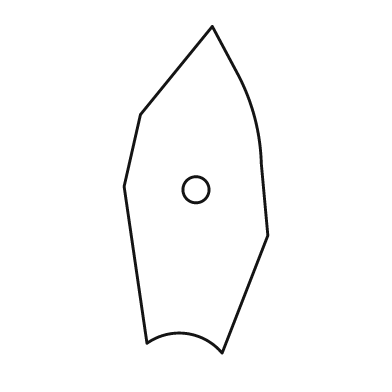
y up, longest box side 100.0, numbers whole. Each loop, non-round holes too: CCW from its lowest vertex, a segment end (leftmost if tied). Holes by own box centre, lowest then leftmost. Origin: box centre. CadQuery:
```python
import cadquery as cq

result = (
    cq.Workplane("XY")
    .moveTo(8.0, -50.0)
    .lineTo(22.0, -14.0)
    .lineTo(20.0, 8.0)
    .threePointArc((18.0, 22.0), (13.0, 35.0))
    .lineTo(5.0, 50.0)
    .lineTo(-17.0, 23.0)
    .lineTo(-22.0, 1.0)
    .lineTo(-15.0, -47.0)
    .threePointArc((-3.0, -44.0), (8.0, -50.0))
    .close()
    .moveTo(0.0, 0.0)
    .circle(4.0)
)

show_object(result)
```